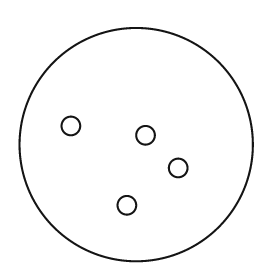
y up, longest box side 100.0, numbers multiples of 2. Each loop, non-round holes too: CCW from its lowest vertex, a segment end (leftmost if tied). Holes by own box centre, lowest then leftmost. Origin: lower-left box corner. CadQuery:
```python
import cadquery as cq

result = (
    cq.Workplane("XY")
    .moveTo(50.0, 50.0)
    .circle(50.0)
    .moveTo(46.0, 24.0)
    .circle(4.0)
    .moveTo(68.0, 40.0)
    .circle(4.0)
    .moveTo(54.0, 54.0)
    .circle(4.0)
    .moveTo(22.0, 58.0)
    .circle(4.0)
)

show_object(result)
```